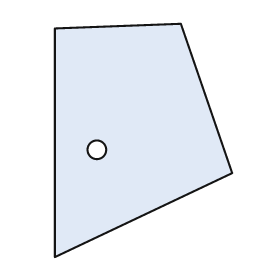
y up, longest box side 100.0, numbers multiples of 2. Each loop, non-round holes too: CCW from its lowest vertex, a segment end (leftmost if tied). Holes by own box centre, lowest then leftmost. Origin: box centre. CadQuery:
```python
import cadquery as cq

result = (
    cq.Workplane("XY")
    .moveTo(-38.0, -50.0)
    .lineTo(38.0, -14.0)
    .lineTo(16.0, 50.0)
    .lineTo(-38.0, 48.0)
    .close()
    .moveTo(-20.0, -4.0)
    .circle(4.0)
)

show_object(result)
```